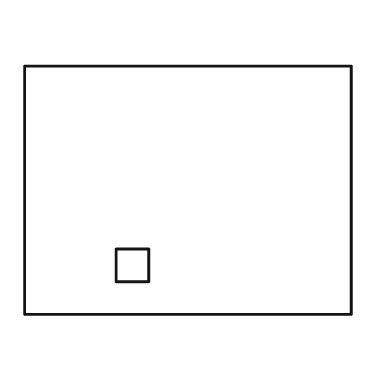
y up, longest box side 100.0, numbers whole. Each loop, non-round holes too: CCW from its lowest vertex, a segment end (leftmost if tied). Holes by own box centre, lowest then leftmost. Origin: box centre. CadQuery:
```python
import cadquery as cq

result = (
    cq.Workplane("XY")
    .moveTo(-50.0, -38.0)
    .lineTo(50.0, -38.0)
    .lineTo(50.0, 38.0)
    .lineTo(-50.0, 38.0)
    .close()
    .moveTo(-22.0, -28.0)
    .lineTo(-12.0, -28.0)
    .lineTo(-12.0, -18.0)
    .lineTo(-22.0, -18.0)
    .close()
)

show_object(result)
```